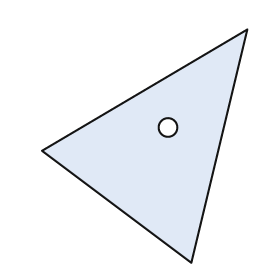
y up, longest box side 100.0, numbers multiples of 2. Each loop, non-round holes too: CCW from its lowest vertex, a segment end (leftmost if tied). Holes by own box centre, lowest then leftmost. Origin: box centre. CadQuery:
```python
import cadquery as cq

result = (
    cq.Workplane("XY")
    .moveTo(20.0, -50.0)
    .lineTo(44.0, 50.0)
    .lineTo(-44.0, -2.0)
    .close()
    .moveTo(10.0, 8.0)
    .circle(4.0)
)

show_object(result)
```